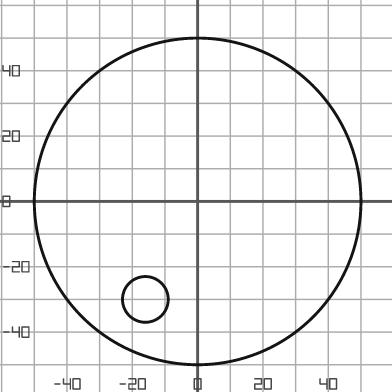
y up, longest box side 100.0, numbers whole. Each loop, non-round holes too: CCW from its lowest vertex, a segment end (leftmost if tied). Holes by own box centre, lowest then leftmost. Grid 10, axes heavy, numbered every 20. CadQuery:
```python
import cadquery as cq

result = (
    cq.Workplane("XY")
    .moveTo(0.0, 0.0)
    .circle(50.0)
    .moveTo(-16.0, -30.0)
    .circle(7.0)
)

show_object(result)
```